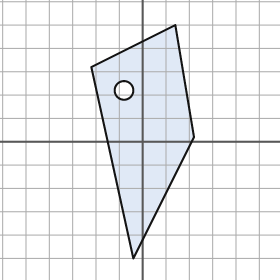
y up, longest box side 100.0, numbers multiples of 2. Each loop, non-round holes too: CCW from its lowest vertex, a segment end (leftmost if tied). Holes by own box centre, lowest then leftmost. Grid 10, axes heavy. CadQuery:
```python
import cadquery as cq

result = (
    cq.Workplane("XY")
    .moveTo(-4.0, -50.0)
    .lineTo(22.0, 2.0)
    .lineTo(14.0, 50.0)
    .lineTo(-22.0, 32.0)
    .close()
    .moveTo(-8.0, 22.0)
    .circle(4.0)
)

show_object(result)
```